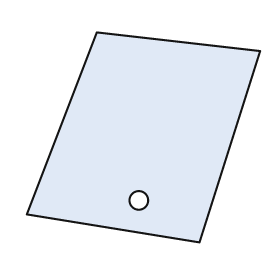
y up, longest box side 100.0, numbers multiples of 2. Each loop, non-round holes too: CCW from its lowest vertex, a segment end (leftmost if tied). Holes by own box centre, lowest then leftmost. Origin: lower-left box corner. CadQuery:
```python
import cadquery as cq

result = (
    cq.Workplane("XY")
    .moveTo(74.0, 0.0)
    .lineTo(100.0, 82.0)
    .lineTo(30.0, 90.0)
    .lineTo(0.0, 12.0)
    .close()
    .moveTo(48.0, 18.0)
    .circle(4.0)
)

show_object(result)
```